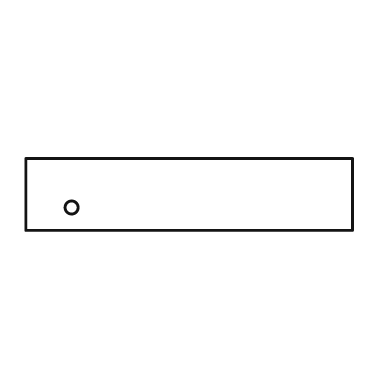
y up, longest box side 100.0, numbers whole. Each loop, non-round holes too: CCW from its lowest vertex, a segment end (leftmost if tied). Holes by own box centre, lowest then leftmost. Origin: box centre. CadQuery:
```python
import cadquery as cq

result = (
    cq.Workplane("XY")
    .moveTo(-50.0, -11.0)
    .lineTo(50.0, -11.0)
    .lineTo(50.0, 11.0)
    .lineTo(-50.0, 11.0)
    .close()
    .moveTo(-36.0, -4.0)
    .circle(2.0)
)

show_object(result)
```